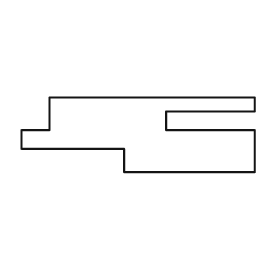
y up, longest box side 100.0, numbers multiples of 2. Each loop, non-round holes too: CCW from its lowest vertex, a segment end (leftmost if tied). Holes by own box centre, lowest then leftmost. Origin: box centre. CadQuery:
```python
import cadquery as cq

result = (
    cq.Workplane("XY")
    .moveTo(-6.0, -16.0)
    .lineTo(50.0, -16.0)
    .lineTo(50.0, 2.0)
    .lineTo(12.0, 2.0)
    .lineTo(12.0, 10.0)
    .lineTo(50.0, 10.0)
    .lineTo(50.0, 16.0)
    .lineTo(-38.0, 16.0)
    .lineTo(-38.0, 2.0)
    .lineTo(-50.0, 2.0)
    .lineTo(-50.0, -6.0)
    .lineTo(-6.0, -6.0)
    .close()
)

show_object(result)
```